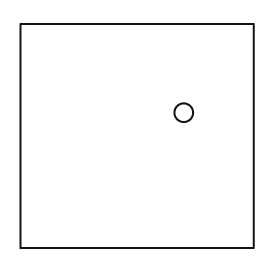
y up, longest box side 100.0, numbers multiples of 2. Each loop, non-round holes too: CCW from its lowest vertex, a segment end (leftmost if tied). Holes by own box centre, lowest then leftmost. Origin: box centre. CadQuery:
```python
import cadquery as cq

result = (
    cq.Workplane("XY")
    .moveTo(-50.0, -48.0)
    .lineTo(50.0, -48.0)
    .lineTo(50.0, 48.0)
    .lineTo(-50.0, 48.0)
    .close()
    .moveTo(20.0, 10.0)
    .circle(4.0)
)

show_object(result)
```